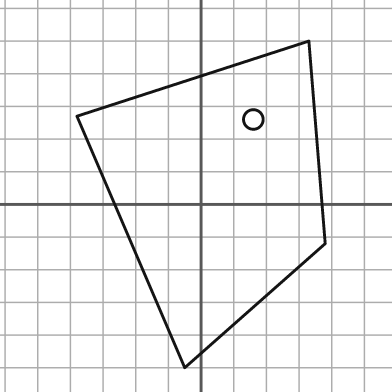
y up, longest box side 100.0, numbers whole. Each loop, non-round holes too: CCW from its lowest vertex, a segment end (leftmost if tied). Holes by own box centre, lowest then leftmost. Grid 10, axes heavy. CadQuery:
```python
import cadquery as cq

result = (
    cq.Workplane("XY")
    .moveTo(-5.0, -50.0)
    .lineTo(38.0, -12.0)
    .lineTo(33.0, 50.0)
    .lineTo(-38.0, 27.0)
    .close()
    .moveTo(16.0, 26.0)
    .circle(3.0)
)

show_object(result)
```